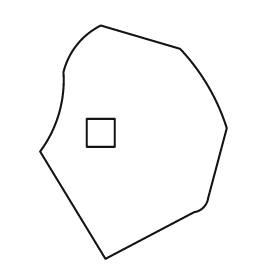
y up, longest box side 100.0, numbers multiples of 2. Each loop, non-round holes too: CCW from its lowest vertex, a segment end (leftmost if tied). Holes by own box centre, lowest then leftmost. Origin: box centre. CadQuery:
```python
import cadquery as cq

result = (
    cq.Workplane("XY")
    .moveTo(-12.0, -50.0)
    .lineTo(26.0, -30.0)
    .threePointArc((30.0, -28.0), (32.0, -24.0))
    .lineTo(40.0, 6.0)
    .threePointArc((32.0, 24.0), (20.0, 40.0))
    .lineTo(-14.0, 50.0)
    .threePointArc((-24.0, 42.0), (-30.0, 30.0))
    .threePointArc((-32.0, 12.0), (-40.0, -4.0))
    .close()
    .moveTo(-20.0, -2.0)
    .lineTo(-8.0, -2.0)
    .lineTo(-8.0, 10.0)
    .lineTo(-20.0, 10.0)
    .close()
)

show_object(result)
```